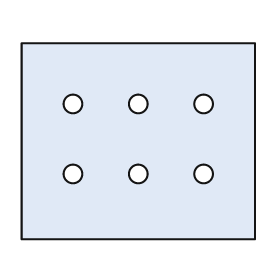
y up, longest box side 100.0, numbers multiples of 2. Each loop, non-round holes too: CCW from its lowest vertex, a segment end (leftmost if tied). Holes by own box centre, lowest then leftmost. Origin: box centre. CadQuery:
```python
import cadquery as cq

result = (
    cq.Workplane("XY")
    .moveTo(-50.0, -42.0)
    .lineTo(50.0, -42.0)
    .lineTo(50.0, 42.0)
    .lineTo(-50.0, 42.0)
    .close()
    .moveTo(-28.0, -14.0)
    .circle(4.0)
    .moveTo(0.0, -14.0)
    .circle(4.0)
    .moveTo(28.0, -14.0)
    .circle(4.0)
    .moveTo(-28.0, 16.0)
    .circle(4.0)
    .moveTo(0.0, 16.0)
    .circle(4.0)
    .moveTo(28.0, 16.0)
    .circle(4.0)
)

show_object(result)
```